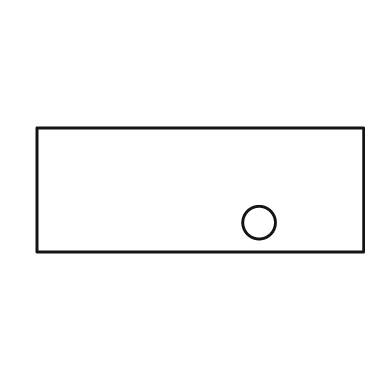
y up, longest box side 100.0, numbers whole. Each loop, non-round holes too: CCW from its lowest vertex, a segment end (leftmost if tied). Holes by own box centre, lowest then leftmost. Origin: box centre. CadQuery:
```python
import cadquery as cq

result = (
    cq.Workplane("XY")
    .moveTo(-50.0, -19.0)
    .lineTo(50.0, -19.0)
    .lineTo(50.0, 19.0)
    .lineTo(-50.0, 19.0)
    .close()
    .moveTo(18.0, -10.0)
    .circle(5.0)
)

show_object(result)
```